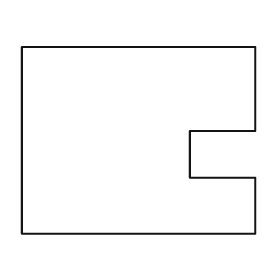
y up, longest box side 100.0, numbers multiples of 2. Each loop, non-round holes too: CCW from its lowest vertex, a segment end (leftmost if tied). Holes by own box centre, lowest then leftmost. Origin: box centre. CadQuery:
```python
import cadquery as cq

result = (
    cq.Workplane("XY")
    .moveTo(-50.0, -40.0)
    .lineTo(50.0, -40.0)
    .lineTo(50.0, -16.0)
    .lineTo(22.0, -16.0)
    .lineTo(22.0, 4.0)
    .lineTo(50.0, 4.0)
    .lineTo(50.0, 40.0)
    .lineTo(-50.0, 40.0)
    .close()
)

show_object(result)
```